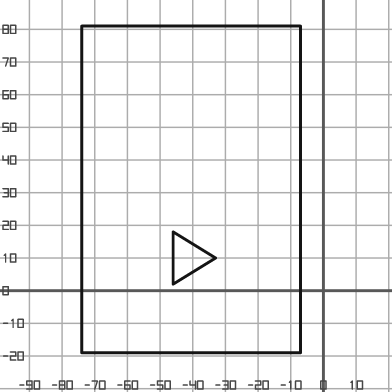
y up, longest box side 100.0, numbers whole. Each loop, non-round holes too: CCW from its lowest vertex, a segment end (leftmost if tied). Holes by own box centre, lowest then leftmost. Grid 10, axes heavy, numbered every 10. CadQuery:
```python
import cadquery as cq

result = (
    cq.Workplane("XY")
    .moveTo(-74.0, -19.0)
    .lineTo(-7.0, -19.0)
    .lineTo(-7.0, 81.0)
    .lineTo(-74.0, 81.0)
    .close()
    .moveTo(-46.0, 2.0)
    .lineTo(-33.0, 10.0)
    .lineTo(-46.0, 18.0)
    .close()
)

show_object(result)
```